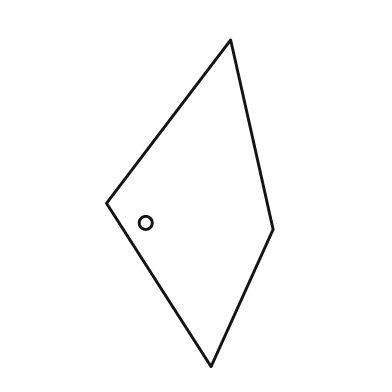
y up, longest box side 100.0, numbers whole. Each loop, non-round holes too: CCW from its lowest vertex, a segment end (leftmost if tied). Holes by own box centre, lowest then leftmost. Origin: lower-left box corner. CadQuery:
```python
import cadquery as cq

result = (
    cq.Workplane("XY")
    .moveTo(32.0, 0.0)
    .lineTo(51.0, 42.0)
    .lineTo(38.0, 100.0)
    .lineTo(0.0, 50.0)
    .close()
    .moveTo(12.0, 44.0)
    .circle(2.0)
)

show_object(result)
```